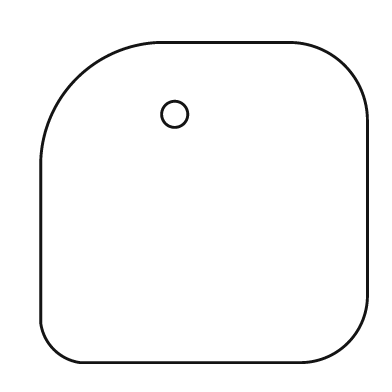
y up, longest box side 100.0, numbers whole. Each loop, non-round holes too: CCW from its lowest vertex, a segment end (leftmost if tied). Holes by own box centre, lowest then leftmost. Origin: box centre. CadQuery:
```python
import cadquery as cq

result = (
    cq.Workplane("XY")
    .moveTo(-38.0, -49.0)
    .lineTo(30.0, -49.0)
    .threePointArc((44.0, -43.0), (50.0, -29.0))
    .lineTo(50.0, 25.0)
    .threePointArc((43.0, 42.0), (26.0, 49.0))
    .lineTo(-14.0, 49.0)
    .threePointArc((-39.0, 38.0), (-50.0, 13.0))
    .lineTo(-50.0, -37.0)
    .threePointArc((-46.0, -45.0), (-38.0, -49.0))
    .close()
    .moveTo(-9.0, 27.0)
    .circle(4.0)
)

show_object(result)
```